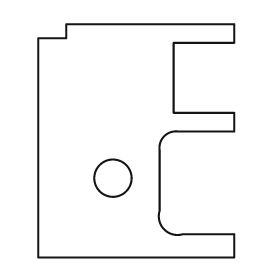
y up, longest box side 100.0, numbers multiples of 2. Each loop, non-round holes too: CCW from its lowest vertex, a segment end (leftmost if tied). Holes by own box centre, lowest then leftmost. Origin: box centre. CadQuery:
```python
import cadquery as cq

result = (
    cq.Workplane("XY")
    .moveTo(-42.0, -50.0)
    .lineTo(42.0, -50.0)
    .lineTo(42.0, -40.0)
    .lineTo(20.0, -40.0)
    .threePointArc((12.0, -38.0), (10.0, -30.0))
    .lineTo(10.0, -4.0)
    .threePointArc((12.0, 2.0), (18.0, 4.0))
    .lineTo(42.0, 4.0)
    .lineTo(42.0, 12.0)
    .lineTo(16.0, 12.0)
    .lineTo(16.0, 42.0)
    .lineTo(42.0, 42.0)
    .lineTo(42.0, 50.0)
    .lineTo(-30.0, 50.0)
    .lineTo(-30.0, 44.0)
    .lineTo(-42.0, 44.0)
    .close()
    .moveTo(-10.0, -16.0)
    .circle(8.0)
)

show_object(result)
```